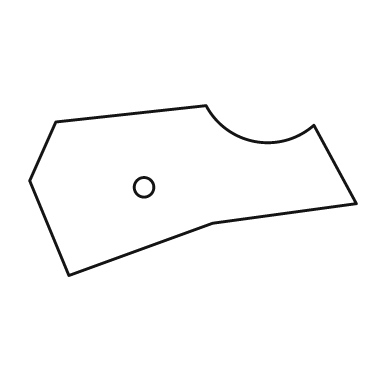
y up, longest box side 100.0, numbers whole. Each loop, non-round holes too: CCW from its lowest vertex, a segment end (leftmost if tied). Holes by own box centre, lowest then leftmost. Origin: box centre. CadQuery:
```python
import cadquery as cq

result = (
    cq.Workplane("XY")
    .moveTo(-38.0, -26.0)
    .lineTo(6.0, -10.0)
    .lineTo(50.0, -4.0)
    .lineTo(37.0, 20.0)
    .threePointArc((19.0, 15.0), (4.0, 26.0))
    .lineTo(-42.0, 21.0)
    .lineTo(-50.0, 3.0)
    .close()
    .moveTo(-15.0, 1.0)
    .circle(3.0)
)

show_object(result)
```